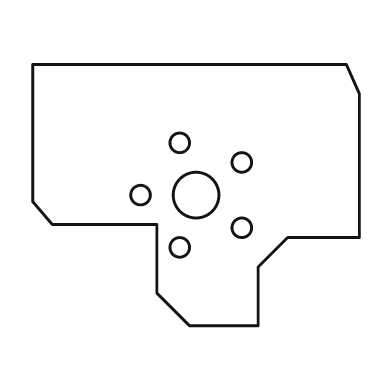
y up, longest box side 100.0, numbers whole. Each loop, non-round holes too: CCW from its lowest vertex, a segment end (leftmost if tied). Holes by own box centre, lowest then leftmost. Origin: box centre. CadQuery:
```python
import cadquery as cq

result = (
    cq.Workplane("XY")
    .moveTo(-2.0, -40.0)
    .lineTo(19.0, -40.0)
    .lineTo(19.0, -22.0)
    .lineTo(28.0, -13.0)
    .lineTo(50.0, -13.0)
    .lineTo(50.0, 31.0)
    .lineTo(46.0, 40.0)
    .lineTo(-50.0, 40.0)
    .lineTo(-50.0, -2.0)
    .lineTo(-44.0, -9.0)
    .lineTo(-12.0, -9.0)
    .lineTo(-12.0, -30.0)
    .close()
    .moveTo(-5.0, -16.0)
    .circle(3.0)
    .moveTo(14.0, -10.0)
    .circle(3.0)
    .moveTo(-17.0, 0.0)
    .circle(3.0)
    .moveTo(0.0, 0.0)
    .circle(7.0)
    .moveTo(14.0, 10.0)
    .circle(3.0)
    .moveTo(-5.0, 16.0)
    .circle(3.0)
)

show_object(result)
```